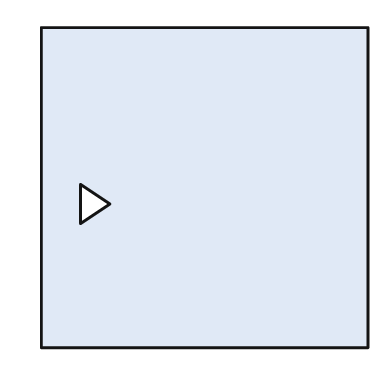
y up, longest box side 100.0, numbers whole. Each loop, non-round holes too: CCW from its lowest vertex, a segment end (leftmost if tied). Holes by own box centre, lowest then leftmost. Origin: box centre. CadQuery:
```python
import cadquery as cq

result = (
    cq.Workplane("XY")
    .moveTo(-50.0, -49.0)
    .lineTo(50.0, -49.0)
    .lineTo(50.0, 49.0)
    .lineTo(-50.0, 49.0)
    .close()
    .moveTo(-38.0, -11.0)
    .lineTo(-29.0, -5.0)
    .lineTo(-38.0, 1.0)
    .close()
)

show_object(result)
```